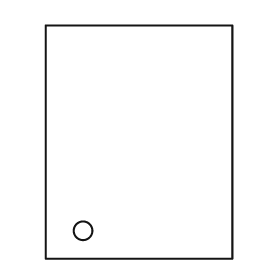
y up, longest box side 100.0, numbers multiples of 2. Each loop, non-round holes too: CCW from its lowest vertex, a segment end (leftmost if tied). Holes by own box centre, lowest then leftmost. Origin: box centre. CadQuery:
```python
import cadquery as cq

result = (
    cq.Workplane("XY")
    .moveTo(-40.0, -50.0)
    .lineTo(40.0, -50.0)
    .lineTo(40.0, 50.0)
    .lineTo(-40.0, 50.0)
    .close()
    .moveTo(-24.0, -38.0)
    .circle(4.0)
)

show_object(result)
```